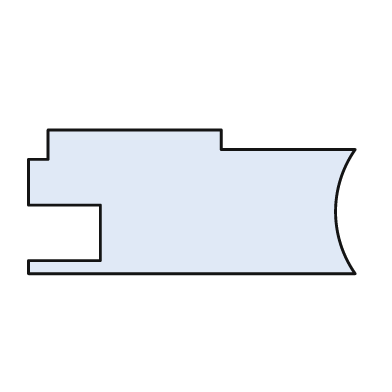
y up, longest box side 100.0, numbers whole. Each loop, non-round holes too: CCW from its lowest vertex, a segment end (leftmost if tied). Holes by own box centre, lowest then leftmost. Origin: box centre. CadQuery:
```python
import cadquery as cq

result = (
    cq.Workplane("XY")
    .moveTo(-50.0, -22.0)
    .lineTo(50.0, -22.0)
    .threePointArc((44.0, -3.0), (50.0, 16.0))
    .lineTo(9.0, 16.0)
    .lineTo(9.0, 22.0)
    .lineTo(-44.0, 22.0)
    .lineTo(-44.0, 13.0)
    .lineTo(-50.0, 13.0)
    .lineTo(-50.0, -1.0)
    .lineTo(-28.0, -1.0)
    .lineTo(-28.0, -18.0)
    .lineTo(-50.0, -18.0)
    .close()
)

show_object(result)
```